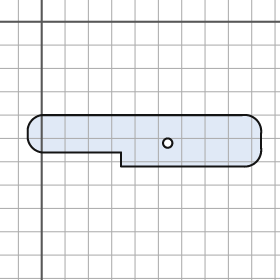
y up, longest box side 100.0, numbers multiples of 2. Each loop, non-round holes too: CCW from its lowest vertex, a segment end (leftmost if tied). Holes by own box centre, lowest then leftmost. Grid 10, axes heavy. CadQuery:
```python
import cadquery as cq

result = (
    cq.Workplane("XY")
    .moveTo(34.0, -62.0)
    .lineTo(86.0, -62.0)
    .threePointArc((92.0, -60.0), (94.0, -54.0))
    .lineTo(94.0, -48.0)
    .threePointArc((92.0, -42.0), (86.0, -40.0))
    .lineTo(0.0, -40.0)
    .threePointArc((-4.0, -42.0), (-6.0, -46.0))
    .lineTo(-6.0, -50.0)
    .threePointArc((-4.0, -54.0), (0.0, -56.0))
    .lineTo(34.0, -56.0)
    .close()
    .moveTo(54.0, -52.0)
    .circle(2.0)
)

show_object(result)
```